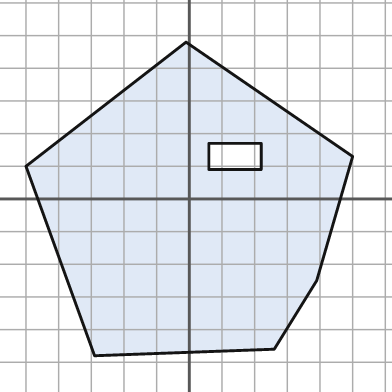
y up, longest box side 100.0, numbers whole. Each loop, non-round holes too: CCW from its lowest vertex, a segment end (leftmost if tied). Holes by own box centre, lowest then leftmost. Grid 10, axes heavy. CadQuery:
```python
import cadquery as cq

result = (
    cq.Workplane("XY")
    .moveTo(-29.0, -48.0)
    .lineTo(26.0, -46.0)
    .lineTo(39.0, -25.0)
    .lineTo(50.0, 13.0)
    .lineTo(-1.0, 48.0)
    .lineTo(-50.0, 10.0)
    .close()
    .moveTo(6.0, 9.0)
    .lineTo(22.0, 9.0)
    .lineTo(22.0, 17.0)
    .lineTo(6.0, 17.0)
    .close()
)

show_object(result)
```